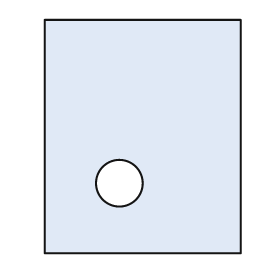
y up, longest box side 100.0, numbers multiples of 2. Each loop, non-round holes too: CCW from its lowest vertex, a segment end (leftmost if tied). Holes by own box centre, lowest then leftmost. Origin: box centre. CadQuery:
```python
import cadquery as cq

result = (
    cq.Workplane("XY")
    .moveTo(-42.0, -50.0)
    .lineTo(42.0, -50.0)
    .lineTo(42.0, 50.0)
    .lineTo(-42.0, 50.0)
    .close()
    .moveTo(-10.0, -20.0)
    .circle(10.0)
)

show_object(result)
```